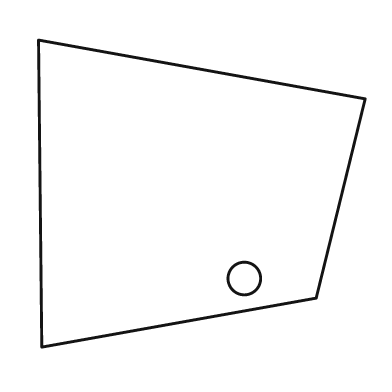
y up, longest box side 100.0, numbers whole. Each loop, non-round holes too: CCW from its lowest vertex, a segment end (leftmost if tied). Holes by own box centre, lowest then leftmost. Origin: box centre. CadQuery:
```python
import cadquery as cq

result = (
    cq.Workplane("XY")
    .moveTo(-49.0, -47.0)
    .lineTo(35.0, -32.0)
    .lineTo(50.0, 29.0)
    .lineTo(-50.0, 47.0)
    .close()
    .moveTo(13.0, -26.0)
    .circle(5.0)
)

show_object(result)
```